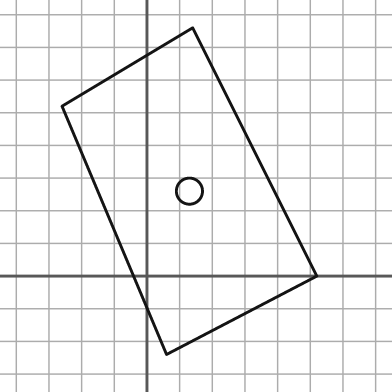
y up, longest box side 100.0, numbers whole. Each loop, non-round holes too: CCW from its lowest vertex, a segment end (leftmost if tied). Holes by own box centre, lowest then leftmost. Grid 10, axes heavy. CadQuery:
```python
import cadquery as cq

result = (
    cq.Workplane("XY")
    .moveTo(6.0, -24.0)
    .lineTo(52.0, 0.0)
    .lineTo(14.0, 76.0)
    .lineTo(-26.0, 52.0)
    .close()
    .moveTo(13.0, 26.0)
    .circle(4.0)
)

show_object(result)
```